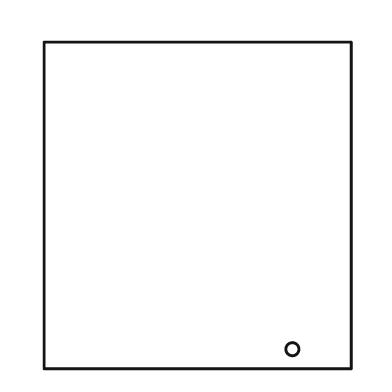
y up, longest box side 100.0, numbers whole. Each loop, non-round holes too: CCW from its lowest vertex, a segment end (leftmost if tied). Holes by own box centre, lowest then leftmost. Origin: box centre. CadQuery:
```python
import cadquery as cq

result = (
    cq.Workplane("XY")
    .moveTo(-47.0, -50.0)
    .lineTo(47.0, -50.0)
    .lineTo(47.0, 50.0)
    .lineTo(-47.0, 50.0)
    .close()
    .moveTo(29.0, -44.0)
    .circle(2.0)
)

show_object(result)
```